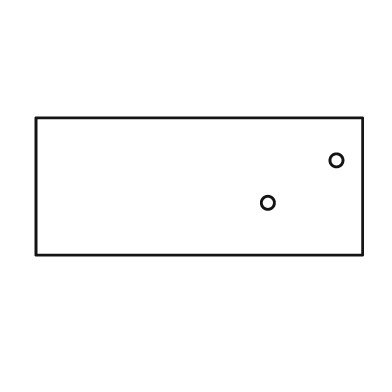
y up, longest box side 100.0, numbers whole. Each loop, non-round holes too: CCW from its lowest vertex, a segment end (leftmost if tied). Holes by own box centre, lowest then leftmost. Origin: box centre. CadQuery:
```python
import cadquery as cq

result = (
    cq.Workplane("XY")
    .moveTo(-50.0, -21.0)
    .lineTo(50.0, -21.0)
    .lineTo(50.0, 21.0)
    .lineTo(-50.0, 21.0)
    .close()
    .moveTo(21.0, -5.0)
    .circle(2.0)
    .moveTo(42.0, 8.0)
    .circle(2.0)
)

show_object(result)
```